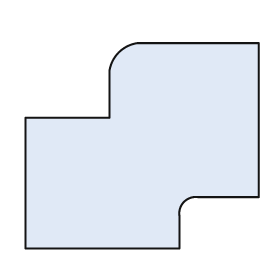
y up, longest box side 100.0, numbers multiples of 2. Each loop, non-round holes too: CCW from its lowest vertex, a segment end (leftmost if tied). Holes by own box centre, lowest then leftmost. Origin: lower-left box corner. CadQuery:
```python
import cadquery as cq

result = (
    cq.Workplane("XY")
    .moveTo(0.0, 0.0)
    .lineTo(66.0, 0.0)
    .lineTo(66.0, 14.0)
    .threePointArc((68.0, 20.0), (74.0, 22.0))
    .lineTo(100.0, 22.0)
    .lineTo(100.0, 88.0)
    .lineTo(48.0, 88.0)
    .threePointArc((40.0, 84.0), (36.0, 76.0))
    .lineTo(36.0, 56.0)
    .lineTo(0.0, 56.0)
    .close()
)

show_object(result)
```